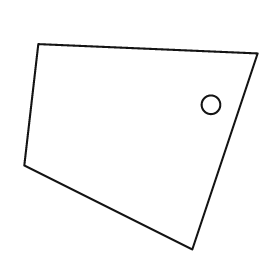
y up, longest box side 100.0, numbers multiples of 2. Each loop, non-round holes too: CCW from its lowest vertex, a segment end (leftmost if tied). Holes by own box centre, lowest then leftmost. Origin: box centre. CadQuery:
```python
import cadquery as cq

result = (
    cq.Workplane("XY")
    .moveTo(22.0, -44.0)
    .lineTo(50.0, 40.0)
    .lineTo(-44.0, 44.0)
    .lineTo(-50.0, -8.0)
    .close()
    .moveTo(30.0, 18.0)
    .circle(4.0)
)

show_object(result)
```